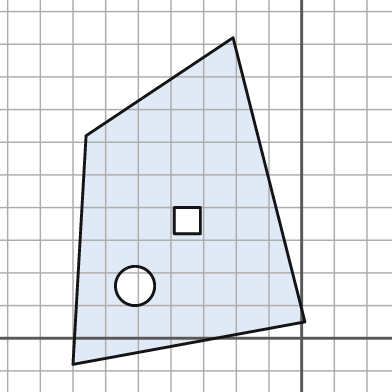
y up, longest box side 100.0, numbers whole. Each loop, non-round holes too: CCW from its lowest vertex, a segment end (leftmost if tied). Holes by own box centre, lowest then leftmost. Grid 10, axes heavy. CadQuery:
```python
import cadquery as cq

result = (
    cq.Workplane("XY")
    .moveTo(-70.0, -8.0)
    .lineTo(1.0, 5.0)
    .lineTo(-21.0, 92.0)
    .lineTo(-66.0, 62.0)
    .close()
    .moveTo(-51.0, 16.0)
    .circle(6.0)
    .moveTo(-39.0, 32.0)
    .lineTo(-31.0, 32.0)
    .lineTo(-31.0, 40.0)
    .lineTo(-39.0, 40.0)
    .close()
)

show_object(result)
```